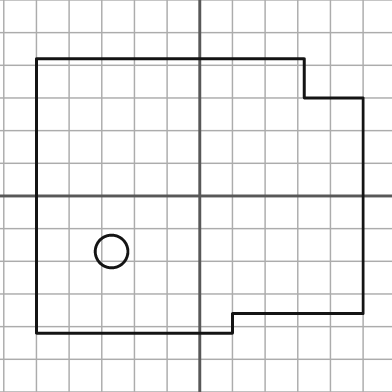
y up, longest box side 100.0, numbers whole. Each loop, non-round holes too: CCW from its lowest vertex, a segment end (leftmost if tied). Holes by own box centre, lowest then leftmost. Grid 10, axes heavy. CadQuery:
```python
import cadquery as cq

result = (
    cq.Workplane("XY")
    .moveTo(-50.0, -42.0)
    .lineTo(10.0, -42.0)
    .lineTo(10.0, -36.0)
    .lineTo(50.0, -36.0)
    .lineTo(50.0, 30.0)
    .lineTo(32.0, 30.0)
    .lineTo(32.0, 42.0)
    .lineTo(-50.0, 42.0)
    .close()
    .moveTo(-27.0, -17.0)
    .circle(5.0)
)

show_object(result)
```